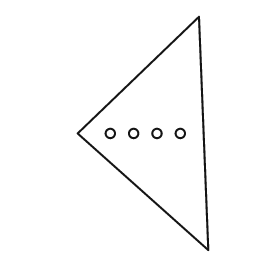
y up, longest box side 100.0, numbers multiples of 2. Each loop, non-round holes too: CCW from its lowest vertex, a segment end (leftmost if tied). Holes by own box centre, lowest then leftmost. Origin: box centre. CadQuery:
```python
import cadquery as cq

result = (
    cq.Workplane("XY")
    .moveTo(28.0, -50.0)
    .lineTo(24.0, 50.0)
    .lineTo(-28.0, 0.0)
    .close()
    .moveTo(-14.0, 0.0)
    .circle(2.0)
    .moveTo(-4.0, 0.0)
    .circle(2.0)
    .moveTo(6.0, 0.0)
    .circle(2.0)
    .moveTo(16.0, 0.0)
    .circle(2.0)
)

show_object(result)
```